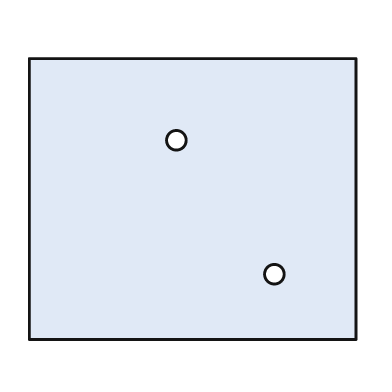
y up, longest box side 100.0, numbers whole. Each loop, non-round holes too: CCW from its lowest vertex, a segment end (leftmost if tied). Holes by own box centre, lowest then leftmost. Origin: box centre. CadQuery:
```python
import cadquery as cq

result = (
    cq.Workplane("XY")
    .moveTo(-50.0, -43.0)
    .lineTo(50.0, -43.0)
    .lineTo(50.0, 43.0)
    .lineTo(-50.0, 43.0)
    .close()
    .moveTo(25.0, -23.0)
    .circle(3.0)
    .moveTo(-5.0, 18.0)
    .circle(3.0)
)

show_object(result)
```